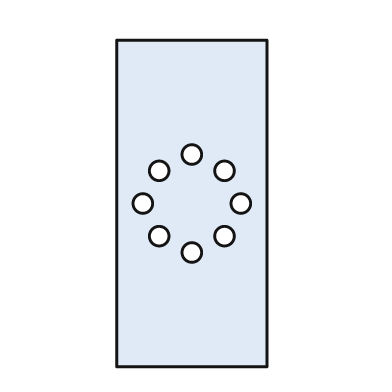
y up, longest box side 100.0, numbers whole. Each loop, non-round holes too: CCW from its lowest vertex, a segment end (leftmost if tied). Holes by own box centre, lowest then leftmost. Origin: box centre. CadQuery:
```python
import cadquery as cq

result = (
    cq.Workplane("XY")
    .moveTo(-23.0, -50.0)
    .lineTo(23.0, -50.0)
    .lineTo(23.0, 50.0)
    .lineTo(-23.0, 50.0)
    .close()
    .moveTo(0.0, -15.0)
    .circle(3.0)
    .moveTo(-10.0, -10.0)
    .circle(3.0)
    .moveTo(10.0, -10.0)
    .circle(3.0)
    .moveTo(-15.0, 0.0)
    .circle(3.0)
    .moveTo(15.0, 0.0)
    .circle(3.0)
    .moveTo(-10.0, 10.0)
    .circle(3.0)
    .moveTo(10.0, 10.0)
    .circle(3.0)
    .moveTo(0.0, 15.0)
    .circle(3.0)
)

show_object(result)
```